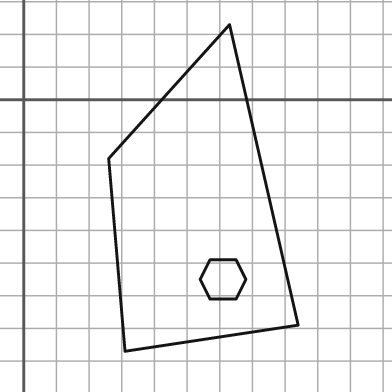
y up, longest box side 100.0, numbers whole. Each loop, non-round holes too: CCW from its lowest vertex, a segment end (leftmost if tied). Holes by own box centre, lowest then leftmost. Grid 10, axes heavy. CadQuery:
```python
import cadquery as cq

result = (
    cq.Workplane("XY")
    .moveTo(31.0, -77.0)
    .lineTo(84.0, -69.0)
    .lineTo(63.0, 23.0)
    .lineTo(26.0, -18.0)
    .close()
    .moveTo(57.0, -61.0)
    .lineTo(65.0, -61.0)
    .lineTo(68.0, -55.0)
    .lineTo(65.0, -49.0)
    .lineTo(57.0, -49.0)
    .lineTo(54.0, -55.0)
    .close()
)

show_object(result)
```